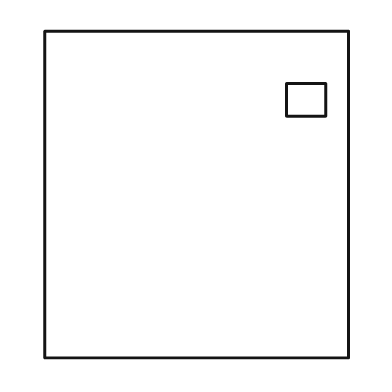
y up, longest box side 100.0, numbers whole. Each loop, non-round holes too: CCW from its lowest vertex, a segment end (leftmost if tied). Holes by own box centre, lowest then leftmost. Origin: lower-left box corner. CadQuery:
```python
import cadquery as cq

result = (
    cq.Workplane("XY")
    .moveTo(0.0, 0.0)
    .lineTo(93.0, 0.0)
    .lineTo(93.0, 100.0)
    .lineTo(0.0, 100.0)
    .close()
    .moveTo(74.0, 74.0)
    .lineTo(86.0, 74.0)
    .lineTo(86.0, 84.0)
    .lineTo(74.0, 84.0)
    .close()
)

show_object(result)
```